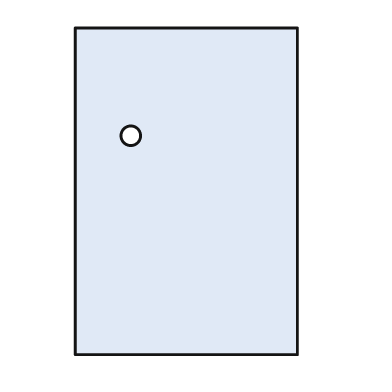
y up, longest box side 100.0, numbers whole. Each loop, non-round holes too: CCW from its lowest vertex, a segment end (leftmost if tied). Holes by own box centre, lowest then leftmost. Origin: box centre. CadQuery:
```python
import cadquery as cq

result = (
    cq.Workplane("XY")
    .moveTo(-34.0, -50.0)
    .lineTo(34.0, -50.0)
    .lineTo(34.0, 50.0)
    .lineTo(-34.0, 50.0)
    .close()
    .moveTo(-17.0, 17.0)
    .circle(3.0)
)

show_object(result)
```